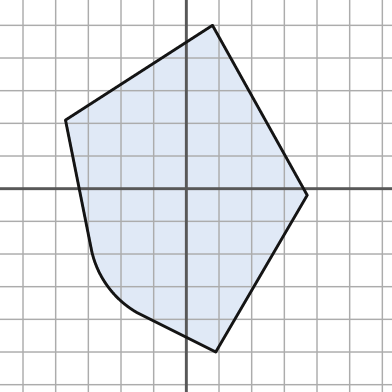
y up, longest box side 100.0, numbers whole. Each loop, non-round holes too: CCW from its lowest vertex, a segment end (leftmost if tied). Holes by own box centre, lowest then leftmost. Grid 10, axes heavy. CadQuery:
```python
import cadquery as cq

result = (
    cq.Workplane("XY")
    .moveTo(9.0, -50.0)
    .lineTo(37.0, -2.0)
    .lineTo(8.0, 50.0)
    .lineTo(-37.0, 21.0)
    .lineTo(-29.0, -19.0)
    .threePointArc((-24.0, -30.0), (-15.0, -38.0))
    .close()
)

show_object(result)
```